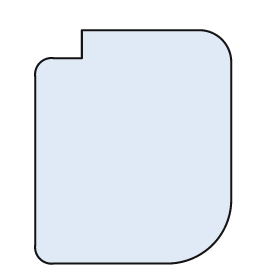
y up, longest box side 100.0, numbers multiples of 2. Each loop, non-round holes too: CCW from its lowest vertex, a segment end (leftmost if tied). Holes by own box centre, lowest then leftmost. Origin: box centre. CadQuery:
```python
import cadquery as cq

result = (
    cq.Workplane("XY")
    .moveTo(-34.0, -50.0)
    .lineTo(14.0, -50.0)
    .threePointArc((34.0, -42.0), (42.0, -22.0))
    .lineTo(42.0, 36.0)
    .threePointArc((38.0, 46.0), (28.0, 50.0))
    .lineTo(-22.0, 50.0)
    .lineTo(-22.0, 38.0)
    .lineTo(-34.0, 38.0)
    .threePointArc((-40.0, 36.0), (-42.0, 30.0))
    .lineTo(-42.0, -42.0)
    .threePointArc((-40.0, -48.0), (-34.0, -50.0))
    .close()
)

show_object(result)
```